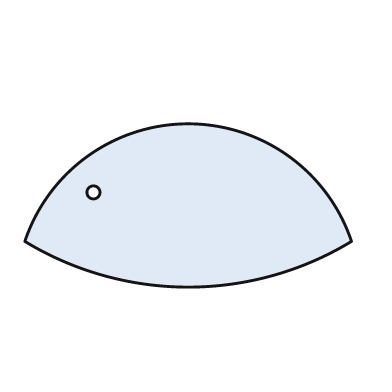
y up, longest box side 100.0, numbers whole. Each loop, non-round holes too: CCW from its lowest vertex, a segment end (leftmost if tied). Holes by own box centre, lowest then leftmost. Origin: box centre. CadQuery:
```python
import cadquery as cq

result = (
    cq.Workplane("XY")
    .moveTo(-50.0, -11.0)
    .threePointArc((0.0, -25.0), (50.0, -11.0))
    .threePointArc((0.0, 25.0), (-50.0, -11.0))
    .close()
    .moveTo(-29.0, 4.0)
    .circle(2.0)
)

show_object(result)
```